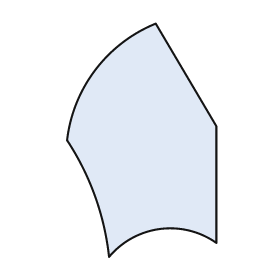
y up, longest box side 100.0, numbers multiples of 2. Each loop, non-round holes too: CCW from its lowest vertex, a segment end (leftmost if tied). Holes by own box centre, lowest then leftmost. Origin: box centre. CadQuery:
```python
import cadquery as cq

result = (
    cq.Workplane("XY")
    .moveTo(-14.0, -50.0)
    .threePointArc((8.0, -38.0), (32.0, -44.0))
    .lineTo(32.0, 6.0)
    .lineTo(6.0, 50.0)
    .threePointArc((-20.0, 30.0), (-32.0, 0.0))
    .threePointArc((-20.0, -24.0), (-14.0, -50.0))
    .close()
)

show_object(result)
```